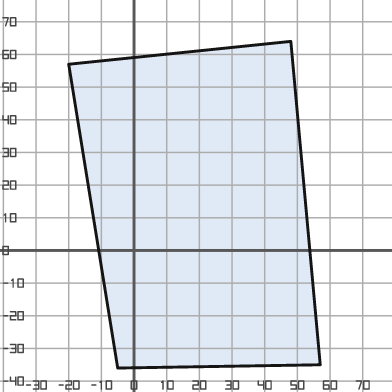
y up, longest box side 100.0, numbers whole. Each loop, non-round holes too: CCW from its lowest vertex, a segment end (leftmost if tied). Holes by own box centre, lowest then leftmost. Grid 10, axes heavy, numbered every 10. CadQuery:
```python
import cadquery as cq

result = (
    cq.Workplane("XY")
    .moveTo(-5.0, -36.0)
    .lineTo(57.0, -35.0)
    .lineTo(48.0, 64.0)
    .lineTo(-20.0, 57.0)
    .close()
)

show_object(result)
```